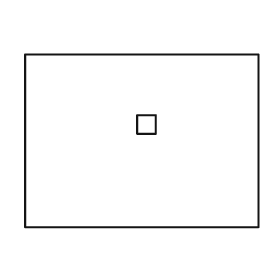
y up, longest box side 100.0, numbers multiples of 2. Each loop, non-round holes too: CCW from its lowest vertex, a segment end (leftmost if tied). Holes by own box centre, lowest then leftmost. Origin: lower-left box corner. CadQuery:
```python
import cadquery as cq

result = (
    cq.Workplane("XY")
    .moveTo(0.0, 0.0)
    .lineTo(100.0, 0.0)
    .lineTo(100.0, 74.0)
    .lineTo(0.0, 74.0)
    .close()
    .moveTo(48.0, 40.0)
    .lineTo(56.0, 40.0)
    .lineTo(56.0, 48.0)
    .lineTo(48.0, 48.0)
    .close()
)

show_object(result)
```